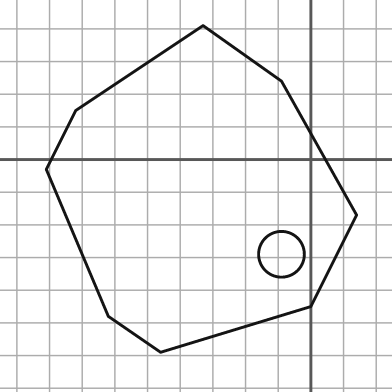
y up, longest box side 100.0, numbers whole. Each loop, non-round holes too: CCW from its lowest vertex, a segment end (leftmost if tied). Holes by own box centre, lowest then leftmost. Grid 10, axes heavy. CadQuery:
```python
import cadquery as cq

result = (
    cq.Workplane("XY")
    .moveTo(-46.0, -59.0)
    .lineTo(0.0, -45.0)
    .lineTo(14.0, -17.0)
    .lineTo(-9.0, 24.0)
    .lineTo(-33.0, 41.0)
    .lineTo(-72.0, 15.0)
    .lineTo(-81.0, -3.0)
    .lineTo(-62.0, -48.0)
    .close()
    .moveTo(-9.0, -29.0)
    .circle(7.0)
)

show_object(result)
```